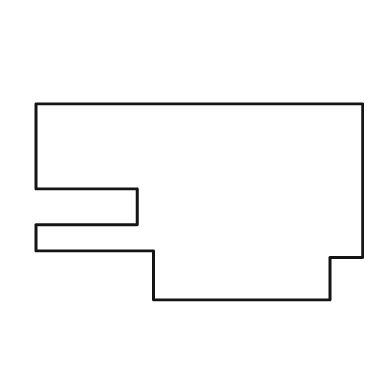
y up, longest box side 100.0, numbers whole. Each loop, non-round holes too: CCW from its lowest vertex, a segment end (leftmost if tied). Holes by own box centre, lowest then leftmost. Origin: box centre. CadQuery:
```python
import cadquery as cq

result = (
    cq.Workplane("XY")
    .moveTo(-14.0, -30.0)
    .lineTo(40.0, -30.0)
    .lineTo(40.0, -17.0)
    .lineTo(50.0, -17.0)
    .lineTo(50.0, 30.0)
    .lineTo(-50.0, 30.0)
    .lineTo(-50.0, 4.0)
    .lineTo(-19.0, 4.0)
    .lineTo(-19.0, -7.0)
    .lineTo(-50.0, -7.0)
    .lineTo(-50.0, -15.0)
    .lineTo(-14.0, -15.0)
    .close()
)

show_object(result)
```